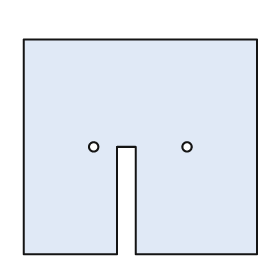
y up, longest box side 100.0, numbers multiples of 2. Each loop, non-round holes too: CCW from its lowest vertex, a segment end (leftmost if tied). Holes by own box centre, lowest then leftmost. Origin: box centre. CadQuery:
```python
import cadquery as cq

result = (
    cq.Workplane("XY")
    .moveTo(-50.0, -46.0)
    .lineTo(-10.0, -46.0)
    .lineTo(-10.0, 0.0)
    .lineTo(-2.0, 0.0)
    .lineTo(-2.0, -46.0)
    .lineTo(50.0, -46.0)
    .lineTo(50.0, 46.0)
    .lineTo(-50.0, 46.0)
    .close()
    .moveTo(-20.0, 0.0)
    .circle(2.0)
    .moveTo(20.0, 0.0)
    .circle(2.0)
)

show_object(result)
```